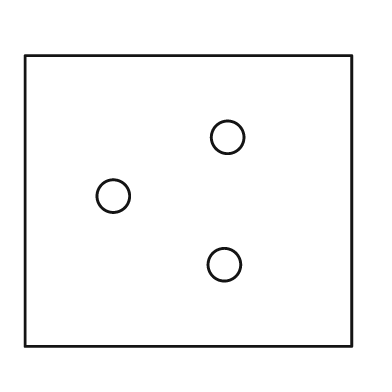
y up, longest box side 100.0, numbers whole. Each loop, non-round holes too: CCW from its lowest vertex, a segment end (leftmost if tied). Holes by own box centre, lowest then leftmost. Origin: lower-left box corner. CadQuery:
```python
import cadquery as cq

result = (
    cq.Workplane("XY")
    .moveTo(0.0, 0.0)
    .lineTo(100.0, 0.0)
    .lineTo(100.0, 89.0)
    .lineTo(0.0, 89.0)
    .close()
    .moveTo(61.0, 25.0)
    .circle(5.0)
    .moveTo(27.0, 46.0)
    .circle(5.0)
    .moveTo(62.0, 64.0)
    .circle(5.0)
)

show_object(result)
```